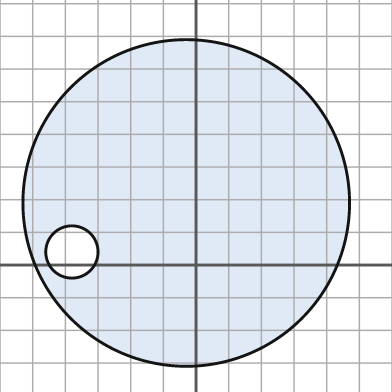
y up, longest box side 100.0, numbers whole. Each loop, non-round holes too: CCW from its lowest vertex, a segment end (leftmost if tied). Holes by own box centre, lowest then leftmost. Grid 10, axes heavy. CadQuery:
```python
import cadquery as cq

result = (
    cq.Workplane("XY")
    .moveTo(-3.0, 19.0)
    .circle(50.0)
    .moveTo(-38.0, 4.0)
    .circle(8.0)
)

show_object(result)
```